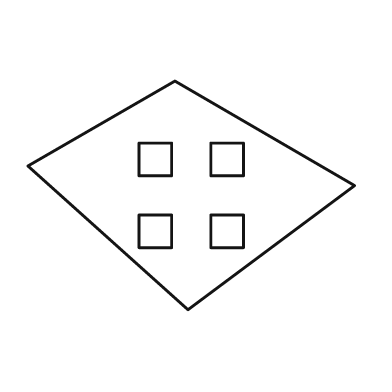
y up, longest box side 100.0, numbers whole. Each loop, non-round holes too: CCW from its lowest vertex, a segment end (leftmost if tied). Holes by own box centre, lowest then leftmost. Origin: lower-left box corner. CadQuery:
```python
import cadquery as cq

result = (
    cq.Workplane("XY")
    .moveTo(49.0, 0.0)
    .lineTo(100.0, 38.0)
    .lineTo(45.0, 70.0)
    .lineTo(0.0, 44.0)
    .close()
    .moveTo(34.0, 19.0)
    .lineTo(44.0, 19.0)
    .lineTo(44.0, 29.0)
    .lineTo(34.0, 29.0)
    .close()
    .moveTo(56.0, 19.0)
    .lineTo(66.0, 19.0)
    .lineTo(66.0, 29.0)
    .lineTo(56.0, 29.0)
    .close()
    .moveTo(34.0, 41.0)
    .lineTo(44.0, 41.0)
    .lineTo(44.0, 51.0)
    .lineTo(34.0, 51.0)
    .close()
    .moveTo(56.0, 41.0)
    .lineTo(66.0, 41.0)
    .lineTo(66.0, 51.0)
    .lineTo(56.0, 51.0)
    .close()
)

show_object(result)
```